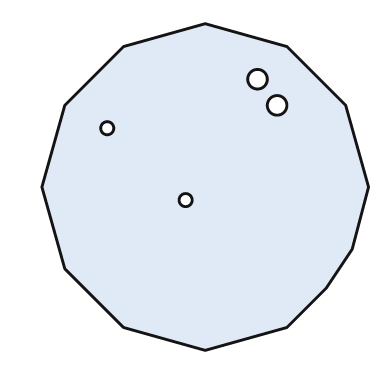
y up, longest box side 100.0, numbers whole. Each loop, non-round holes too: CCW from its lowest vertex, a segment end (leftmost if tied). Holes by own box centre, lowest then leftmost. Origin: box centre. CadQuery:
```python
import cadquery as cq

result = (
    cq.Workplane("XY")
    .moveTo(0.0, -50.0)
    .lineTo(25.0, -43.0)
    .lineTo(37.0, -31.0)
    .lineTo(45.0, -19.0)
    .lineTo(50.0, 0.0)
    .lineTo(43.0, 25.0)
    .lineTo(25.0, 43.0)
    .lineTo(0.0, 50.0)
    .lineTo(-25.0, 43.0)
    .lineTo(-43.0, 25.0)
    .lineTo(-50.0, 0.0)
    .lineTo(-43.0, -25.0)
    .lineTo(-25.0, -43.0)
    .close()
    .moveTo(-6.0, -4.0)
    .circle(2.0)
    .moveTo(-30.0, 18.0)
    .circle(2.0)
    .moveTo(22.0, 25.0)
    .circle(3.0)
    .moveTo(16.0, 33.0)
    .circle(3.0)
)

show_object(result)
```